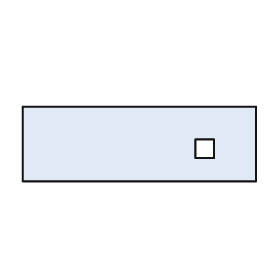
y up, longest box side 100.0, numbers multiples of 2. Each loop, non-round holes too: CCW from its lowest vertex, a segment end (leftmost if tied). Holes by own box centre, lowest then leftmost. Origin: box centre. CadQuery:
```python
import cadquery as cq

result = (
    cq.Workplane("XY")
    .moveTo(-50.0, -16.0)
    .lineTo(50.0, -16.0)
    .lineTo(50.0, 16.0)
    .lineTo(-50.0, 16.0)
    .close()
    .moveTo(24.0, -6.0)
    .lineTo(32.0, -6.0)
    .lineTo(32.0, 2.0)
    .lineTo(24.0, 2.0)
    .close()
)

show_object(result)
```